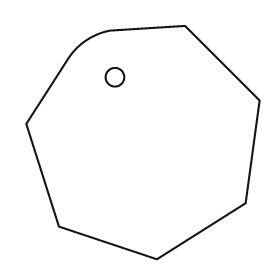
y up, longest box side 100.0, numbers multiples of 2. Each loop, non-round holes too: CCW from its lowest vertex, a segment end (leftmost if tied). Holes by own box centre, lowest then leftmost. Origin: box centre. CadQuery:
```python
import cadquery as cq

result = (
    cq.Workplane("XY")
    .moveTo(6.0, -50.0)
    .lineTo(44.0, -26.0)
    .lineTo(50.0, 18.0)
    .lineTo(18.0, 50.0)
    .lineTo(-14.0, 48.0)
    .threePointArc((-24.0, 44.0), (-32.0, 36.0))
    .lineTo(-50.0, 8.0)
    .lineTo(-36.0, -36.0)
    .close()
    .moveTo(-12.0, 28.0)
    .circle(4.0)
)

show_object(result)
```